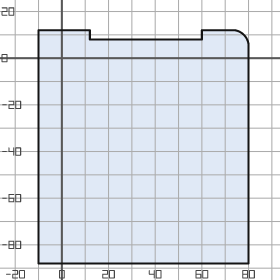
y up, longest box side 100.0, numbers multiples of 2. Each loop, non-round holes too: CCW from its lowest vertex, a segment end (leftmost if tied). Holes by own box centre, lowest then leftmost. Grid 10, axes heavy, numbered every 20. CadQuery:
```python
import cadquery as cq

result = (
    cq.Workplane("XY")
    .moveTo(-10.0, -88.0)
    .lineTo(80.0, -88.0)
    .lineTo(80.0, 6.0)
    .threePointArc((78.0, 10.0), (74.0, 12.0))
    .lineTo(60.0, 12.0)
    .lineTo(60.0, 8.0)
    .lineTo(12.0, 8.0)
    .lineTo(12.0, 12.0)
    .lineTo(-10.0, 12.0)
    .close()
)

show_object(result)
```